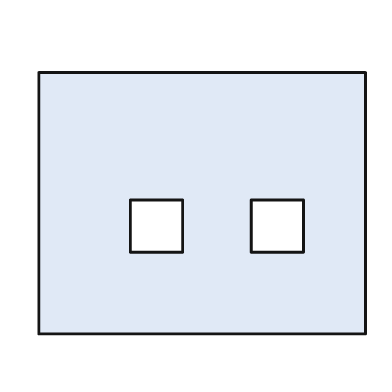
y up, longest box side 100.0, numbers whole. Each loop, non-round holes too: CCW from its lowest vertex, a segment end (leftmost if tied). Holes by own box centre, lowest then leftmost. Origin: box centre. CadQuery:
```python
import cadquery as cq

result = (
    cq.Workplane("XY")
    .moveTo(-50.0, -40.0)
    .lineTo(50.0, -40.0)
    .lineTo(50.0, 40.0)
    .lineTo(-50.0, 40.0)
    .close()
    .moveTo(-22.0, -15.0)
    .lineTo(-6.0, -15.0)
    .lineTo(-6.0, 1.0)
    .lineTo(-22.0, 1.0)
    .close()
    .moveTo(15.0, -15.0)
    .lineTo(31.0, -15.0)
    .lineTo(31.0, 1.0)
    .lineTo(15.0, 1.0)
    .close()
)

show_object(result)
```